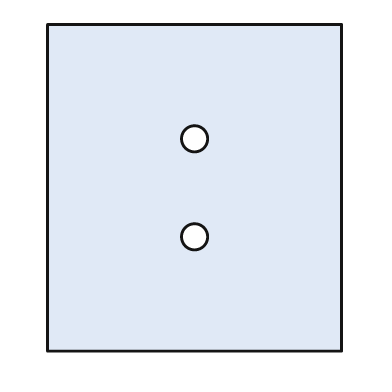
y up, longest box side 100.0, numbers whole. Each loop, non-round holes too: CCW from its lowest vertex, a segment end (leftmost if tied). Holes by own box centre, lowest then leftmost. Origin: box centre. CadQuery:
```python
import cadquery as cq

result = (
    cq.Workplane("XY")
    .moveTo(-45.0, -50.0)
    .lineTo(45.0, -50.0)
    .lineTo(45.0, 50.0)
    .lineTo(-45.0, 50.0)
    .close()
    .moveTo(0.0, -15.0)
    .circle(4.0)
    .moveTo(0.0, 15.0)
    .circle(4.0)
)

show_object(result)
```